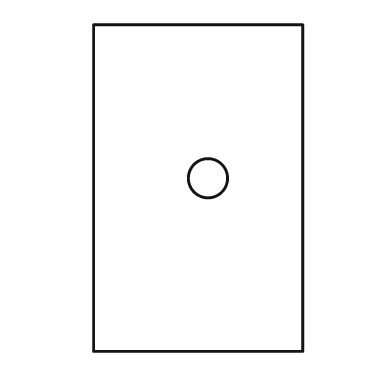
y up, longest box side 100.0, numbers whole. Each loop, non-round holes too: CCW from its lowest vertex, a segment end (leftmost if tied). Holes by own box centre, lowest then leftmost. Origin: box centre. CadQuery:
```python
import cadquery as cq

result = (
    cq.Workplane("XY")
    .moveTo(-32.0, -50.0)
    .lineTo(32.0, -50.0)
    .lineTo(32.0, 50.0)
    .lineTo(-32.0, 50.0)
    .close()
    .moveTo(3.0, 3.0)
    .circle(6.0)
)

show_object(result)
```